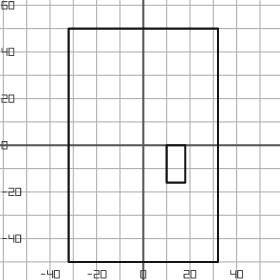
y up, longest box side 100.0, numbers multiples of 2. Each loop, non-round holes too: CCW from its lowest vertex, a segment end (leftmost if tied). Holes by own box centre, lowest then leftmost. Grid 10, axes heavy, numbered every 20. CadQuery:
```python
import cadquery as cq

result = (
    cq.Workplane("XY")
    .moveTo(-32.0, -50.0)
    .lineTo(32.0, -50.0)
    .lineTo(32.0, 50.0)
    .lineTo(-32.0, 50.0)
    .close()
    .moveTo(10.0, -16.0)
    .lineTo(18.0, -16.0)
    .lineTo(18.0, 0.0)
    .lineTo(10.0, 0.0)
    .close()
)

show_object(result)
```